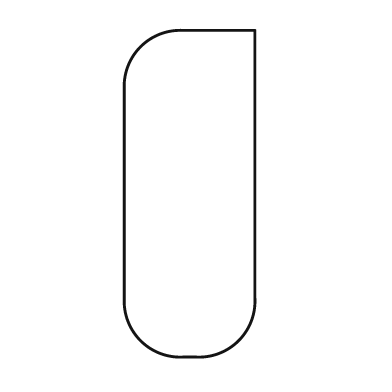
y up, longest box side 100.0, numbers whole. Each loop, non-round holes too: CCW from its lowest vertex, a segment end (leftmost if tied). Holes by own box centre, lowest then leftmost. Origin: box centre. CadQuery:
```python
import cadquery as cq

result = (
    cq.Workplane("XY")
    .moveTo(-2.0, -50.0)
    .lineTo(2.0, -50.0)
    .threePointArc((15.0, -45.0), (20.0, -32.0))
    .lineTo(20.0, 50.0)
    .lineTo(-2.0, 50.0)
    .threePointArc((-15.0, 45.0), (-20.0, 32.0))
    .lineTo(-20.0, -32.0)
    .threePointArc((-15.0, -45.0), (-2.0, -50.0))
    .close()
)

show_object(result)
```